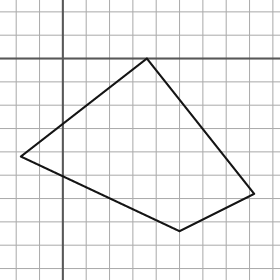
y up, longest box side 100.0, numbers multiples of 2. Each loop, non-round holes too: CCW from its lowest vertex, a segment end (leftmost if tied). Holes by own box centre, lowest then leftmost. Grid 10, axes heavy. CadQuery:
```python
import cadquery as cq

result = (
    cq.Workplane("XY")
    .moveTo(50.0, -74.0)
    .lineTo(82.0, -58.0)
    .lineTo(36.0, 0.0)
    .lineTo(-18.0, -42.0)
    .close()
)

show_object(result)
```